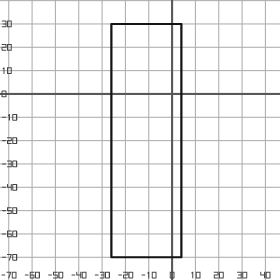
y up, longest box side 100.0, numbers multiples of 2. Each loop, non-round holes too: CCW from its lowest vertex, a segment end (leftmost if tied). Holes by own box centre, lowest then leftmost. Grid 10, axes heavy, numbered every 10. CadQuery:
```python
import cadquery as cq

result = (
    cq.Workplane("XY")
    .moveTo(-26.0, -70.0)
    .lineTo(4.0, -70.0)
    .lineTo(4.0, 30.0)
    .lineTo(-26.0, 30.0)
    .close()
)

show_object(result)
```